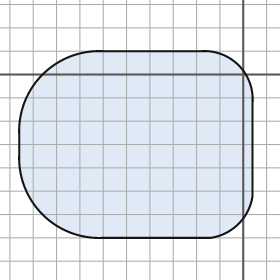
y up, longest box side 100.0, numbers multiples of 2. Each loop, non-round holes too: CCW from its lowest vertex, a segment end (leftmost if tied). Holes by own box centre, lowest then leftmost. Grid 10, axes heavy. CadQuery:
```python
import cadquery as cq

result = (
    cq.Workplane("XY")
    .moveTo(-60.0, -70.0)
    .lineTo(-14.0, -70.0)
    .threePointArc((-2.0, -64.0), (4.0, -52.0))
    .lineTo(4.0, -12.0)
    .threePointArc((-2.0, 4.0), (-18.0, 10.0))
    .lineTo(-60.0, 10.0)
    .threePointArc((-86.0, 0.0), (-96.0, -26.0))
    .lineTo(-96.0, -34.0)
    .threePointArc((-86.0, -60.0), (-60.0, -70.0))
    .close()
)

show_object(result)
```